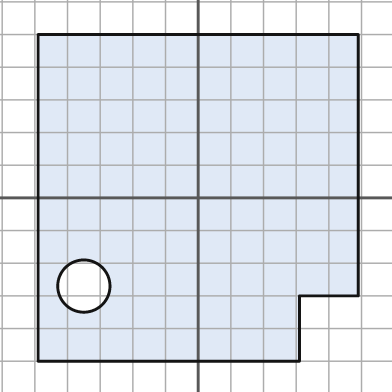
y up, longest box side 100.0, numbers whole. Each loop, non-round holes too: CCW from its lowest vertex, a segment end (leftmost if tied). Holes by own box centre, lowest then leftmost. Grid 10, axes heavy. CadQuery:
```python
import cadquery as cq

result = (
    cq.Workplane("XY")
    .moveTo(-49.0, -50.0)
    .lineTo(31.0, -50.0)
    .lineTo(31.0, -30.0)
    .lineTo(49.0, -30.0)
    .lineTo(49.0, 50.0)
    .lineTo(-49.0, 50.0)
    .close()
    .moveTo(-35.0, -27.0)
    .circle(8.0)
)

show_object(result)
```